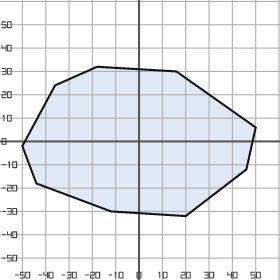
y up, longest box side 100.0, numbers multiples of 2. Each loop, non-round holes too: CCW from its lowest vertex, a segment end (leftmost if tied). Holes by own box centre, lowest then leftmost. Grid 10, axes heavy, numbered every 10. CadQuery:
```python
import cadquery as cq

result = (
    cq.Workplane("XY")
    .moveTo(20.0, -32.0)
    .lineTo(46.0, -12.0)
    .lineTo(50.0, 6.0)
    .lineTo(16.0, 30.0)
    .lineTo(-18.0, 32.0)
    .lineTo(-36.0, 24.0)
    .lineTo(-50.0, -2.0)
    .lineTo(-44.0, -18.0)
    .lineTo(-12.0, -30.0)
    .close()
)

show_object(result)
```